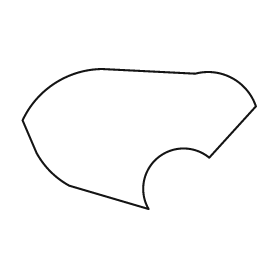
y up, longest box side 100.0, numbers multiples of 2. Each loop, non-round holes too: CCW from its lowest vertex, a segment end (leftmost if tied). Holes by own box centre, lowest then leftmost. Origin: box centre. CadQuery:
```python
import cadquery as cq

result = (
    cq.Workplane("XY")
    .moveTo(4.0, -30.0)
    .threePointArc((8.0, -8.0), (30.0, -8.0))
    .lineTo(50.0, 14.0)
    .threePointArc((40.0, 26.0), (24.0, 28.0))
    .lineTo(-16.0, 30.0)
    .threePointArc((-36.0, 24.0), (-50.0, 8.0))
    .lineTo(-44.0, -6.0)
    .threePointArc((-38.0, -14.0), (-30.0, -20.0))
    .close()
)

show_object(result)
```